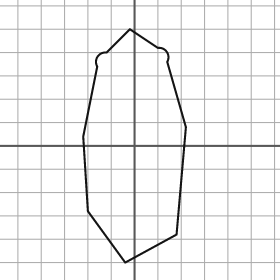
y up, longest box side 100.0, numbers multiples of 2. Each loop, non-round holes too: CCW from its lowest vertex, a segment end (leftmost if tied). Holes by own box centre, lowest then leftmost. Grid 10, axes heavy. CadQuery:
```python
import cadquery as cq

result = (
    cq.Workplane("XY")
    .moveTo(-4.0, -50.0)
    .lineTo(18.0, -38.0)
    .lineTo(22.0, 8.0)
    .lineTo(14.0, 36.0)
    .threePointArc((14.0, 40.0), (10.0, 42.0))
    .lineTo(-2.0, 50.0)
    .lineTo(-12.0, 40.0)
    .threePointArc((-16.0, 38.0), (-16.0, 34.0))
    .lineTo(-22.0, 4.0)
    .lineTo(-20.0, -28.0)
    .close()
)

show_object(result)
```